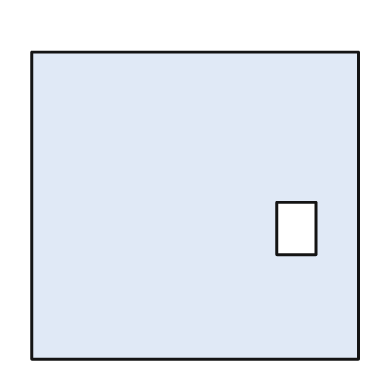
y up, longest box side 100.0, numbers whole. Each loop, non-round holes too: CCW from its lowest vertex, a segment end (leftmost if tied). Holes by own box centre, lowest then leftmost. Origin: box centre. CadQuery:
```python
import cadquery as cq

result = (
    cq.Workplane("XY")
    .moveTo(-50.0, -47.0)
    .lineTo(50.0, -47.0)
    .lineTo(50.0, 47.0)
    .lineTo(-50.0, 47.0)
    .close()
    .moveTo(25.0, -15.0)
    .lineTo(37.0, -15.0)
    .lineTo(37.0, 1.0)
    .lineTo(25.0, 1.0)
    .close()
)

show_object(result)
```